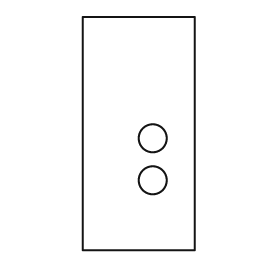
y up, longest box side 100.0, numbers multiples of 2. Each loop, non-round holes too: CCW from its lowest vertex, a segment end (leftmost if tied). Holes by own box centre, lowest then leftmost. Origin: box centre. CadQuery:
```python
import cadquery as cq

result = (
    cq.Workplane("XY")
    .moveTo(-24.0, -50.0)
    .lineTo(24.0, -50.0)
    .lineTo(24.0, 50.0)
    .lineTo(-24.0, 50.0)
    .close()
    .moveTo(6.0, -20.0)
    .circle(6.0)
    .moveTo(6.0, -2.0)
    .circle(6.0)
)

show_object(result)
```